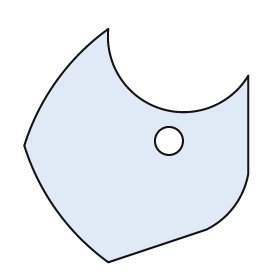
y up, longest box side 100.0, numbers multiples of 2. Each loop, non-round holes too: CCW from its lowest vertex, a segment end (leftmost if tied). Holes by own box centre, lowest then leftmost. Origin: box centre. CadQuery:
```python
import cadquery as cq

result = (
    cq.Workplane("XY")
    .moveTo(-12.0, -50.0)
    .lineTo(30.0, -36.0)
    .threePointArc((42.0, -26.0), (48.0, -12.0))
    .lineTo(48.0, 30.0)
    .threePointArc((10.0, 16.0), (-12.0, 50.0))
    .threePointArc((-34.0, 28.0), (-48.0, 0.0))
    .threePointArc((-34.0, -28.0), (-12.0, -50.0))
    .close()
    .moveTo(14.0, 2.0)
    .circle(6.0)
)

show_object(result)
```